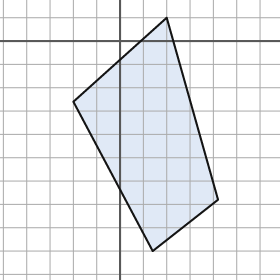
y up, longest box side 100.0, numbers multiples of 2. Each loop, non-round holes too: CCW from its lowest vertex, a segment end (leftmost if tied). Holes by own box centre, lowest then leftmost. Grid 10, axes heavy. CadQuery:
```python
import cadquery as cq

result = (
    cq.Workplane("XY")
    .moveTo(14.0, -90.0)
    .lineTo(42.0, -68.0)
    .lineTo(20.0, 10.0)
    .lineTo(-20.0, -26.0)
    .close()
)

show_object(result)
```